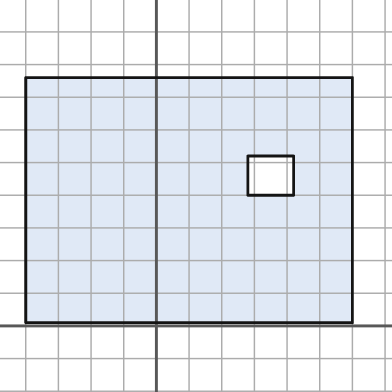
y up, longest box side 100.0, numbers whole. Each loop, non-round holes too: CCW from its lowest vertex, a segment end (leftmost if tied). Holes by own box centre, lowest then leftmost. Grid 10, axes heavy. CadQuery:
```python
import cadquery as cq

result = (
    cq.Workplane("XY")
    .moveTo(-40.0, 1.0)
    .lineTo(60.0, 1.0)
    .lineTo(60.0, 76.0)
    .lineTo(-40.0, 76.0)
    .close()
    .moveTo(28.0, 40.0)
    .lineTo(42.0, 40.0)
    .lineTo(42.0, 52.0)
    .lineTo(28.0, 52.0)
    .close()
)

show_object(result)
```